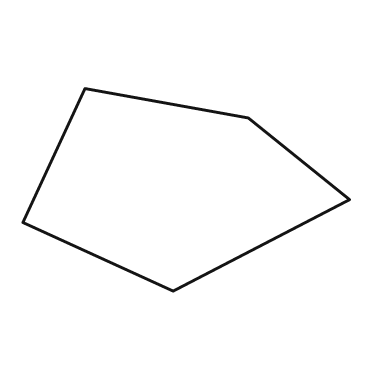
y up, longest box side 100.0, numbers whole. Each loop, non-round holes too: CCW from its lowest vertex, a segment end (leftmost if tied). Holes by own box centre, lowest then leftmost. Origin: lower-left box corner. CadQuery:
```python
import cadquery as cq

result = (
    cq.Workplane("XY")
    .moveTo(46.0, 0.0)
    .lineTo(100.0, 28.0)
    .lineTo(69.0, 53.0)
    .lineTo(19.0, 62.0)
    .lineTo(0.0, 21.0)
    .close()
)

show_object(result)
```